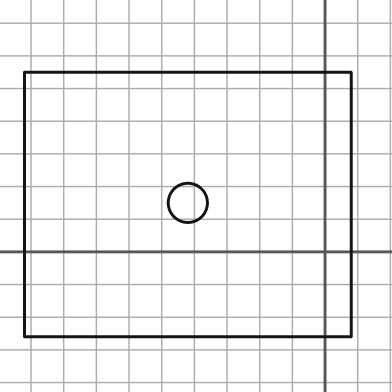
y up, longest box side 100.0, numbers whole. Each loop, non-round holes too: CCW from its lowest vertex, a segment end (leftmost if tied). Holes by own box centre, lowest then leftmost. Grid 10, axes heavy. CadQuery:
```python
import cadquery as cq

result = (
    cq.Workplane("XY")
    .moveTo(-92.0, -26.0)
    .lineTo(8.0, -26.0)
    .lineTo(8.0, 55.0)
    .lineTo(-92.0, 55.0)
    .close()
    .moveTo(-42.0, 15.0)
    .circle(6.0)
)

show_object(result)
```